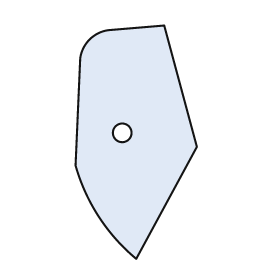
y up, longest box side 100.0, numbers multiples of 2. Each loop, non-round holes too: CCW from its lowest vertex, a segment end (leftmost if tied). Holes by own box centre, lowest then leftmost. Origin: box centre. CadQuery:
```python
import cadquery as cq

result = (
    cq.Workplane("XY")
    .moveTo(0.0, -50.0)
    .lineTo(26.0, -2.0)
    .lineTo(12.0, 50.0)
    .lineTo(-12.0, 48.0)
    .threePointArc((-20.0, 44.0), (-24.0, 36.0))
    .lineTo(-26.0, -10.0)
    .threePointArc((-16.0, -32.0), (0.0, -50.0))
    .close()
    .moveTo(-6.0, 4.0)
    .circle(4.0)
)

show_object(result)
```